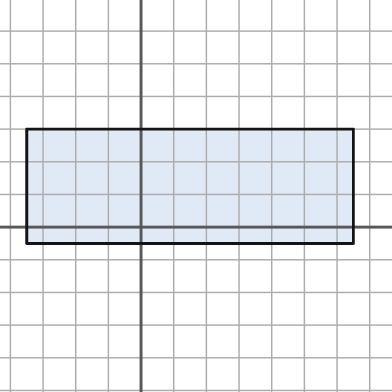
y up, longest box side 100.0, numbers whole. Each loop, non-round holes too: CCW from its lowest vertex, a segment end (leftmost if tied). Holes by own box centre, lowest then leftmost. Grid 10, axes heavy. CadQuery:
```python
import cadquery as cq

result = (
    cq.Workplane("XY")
    .moveTo(-35.0, -5.0)
    .lineTo(65.0, -5.0)
    .lineTo(65.0, 30.0)
    .lineTo(-35.0, 30.0)
    .close()
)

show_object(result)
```